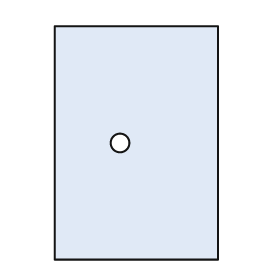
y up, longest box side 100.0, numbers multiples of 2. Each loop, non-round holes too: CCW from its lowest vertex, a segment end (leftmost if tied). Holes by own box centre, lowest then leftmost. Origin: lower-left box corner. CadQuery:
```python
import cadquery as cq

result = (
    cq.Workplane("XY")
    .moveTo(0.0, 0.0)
    .lineTo(70.0, 0.0)
    .lineTo(70.0, 100.0)
    .lineTo(0.0, 100.0)
    .close()
    .moveTo(28.0, 50.0)
    .circle(4.0)
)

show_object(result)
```